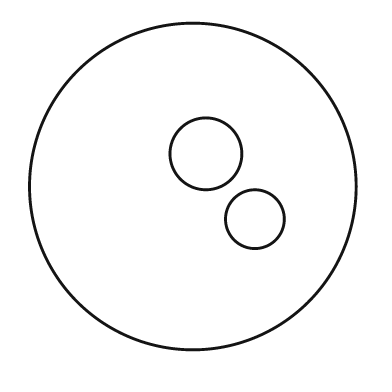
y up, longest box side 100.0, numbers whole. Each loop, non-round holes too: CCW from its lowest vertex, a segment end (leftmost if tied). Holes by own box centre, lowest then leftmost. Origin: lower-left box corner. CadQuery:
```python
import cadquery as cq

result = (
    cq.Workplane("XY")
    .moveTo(50.0, 50.0)
    .circle(50.0)
    .moveTo(69.0, 40.0)
    .circle(9.0)
    .moveTo(54.0, 60.0)
    .circle(11.0)
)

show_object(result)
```